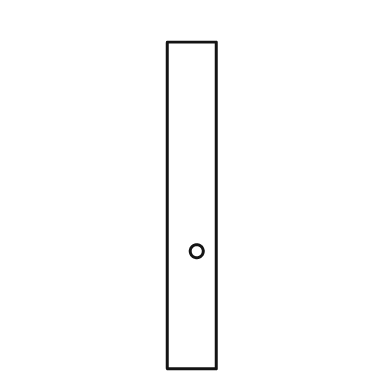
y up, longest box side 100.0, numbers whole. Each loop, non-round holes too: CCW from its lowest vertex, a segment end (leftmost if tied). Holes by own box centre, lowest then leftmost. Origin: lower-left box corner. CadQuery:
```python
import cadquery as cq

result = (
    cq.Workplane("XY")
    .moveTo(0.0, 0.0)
    .lineTo(15.0, 0.0)
    .lineTo(15.0, 100.0)
    .lineTo(0.0, 100.0)
    .close()
    .moveTo(9.0, 36.0)
    .circle(2.0)
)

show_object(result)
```